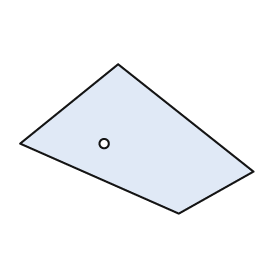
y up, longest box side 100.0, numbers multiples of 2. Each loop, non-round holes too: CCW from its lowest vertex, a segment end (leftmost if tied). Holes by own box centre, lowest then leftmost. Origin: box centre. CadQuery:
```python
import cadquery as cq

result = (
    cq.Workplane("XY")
    .moveTo(18.0, -32.0)
    .lineTo(50.0, -14.0)
    .lineTo(-8.0, 32.0)
    .lineTo(-50.0, -2.0)
    .close()
    .moveTo(-14.0, -2.0)
    .circle(2.0)
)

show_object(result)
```